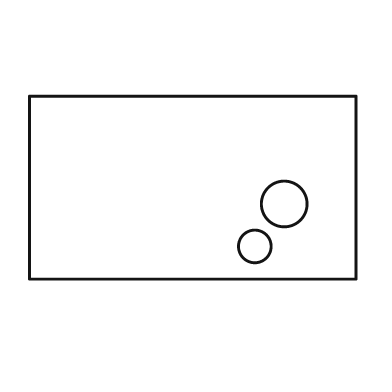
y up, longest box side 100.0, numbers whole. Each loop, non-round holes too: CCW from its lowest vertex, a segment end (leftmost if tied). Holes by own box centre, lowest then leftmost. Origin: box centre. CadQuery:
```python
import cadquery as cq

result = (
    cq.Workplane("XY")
    .moveTo(-50.0, -28.0)
    .lineTo(50.0, -28.0)
    .lineTo(50.0, 28.0)
    .lineTo(-50.0, 28.0)
    .close()
    .moveTo(19.0, -18.0)
    .circle(5.0)
    .moveTo(28.0, -5.0)
    .circle(7.0)
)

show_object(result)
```